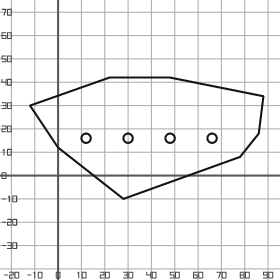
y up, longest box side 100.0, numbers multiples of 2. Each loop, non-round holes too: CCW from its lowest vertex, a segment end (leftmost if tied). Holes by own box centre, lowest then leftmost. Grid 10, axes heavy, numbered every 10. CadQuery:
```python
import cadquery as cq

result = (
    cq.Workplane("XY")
    .moveTo(28.0, -10.0)
    .lineTo(78.0, 8.0)
    .lineTo(86.0, 18.0)
    .lineTo(88.0, 34.0)
    .lineTo(48.0, 42.0)
    .lineTo(22.0, 42.0)
    .lineTo(-12.0, 30.0)
    .lineTo(0.0, 12.0)
    .close()
    .moveTo(12.0, 16.0)
    .circle(2.0)
    .moveTo(30.0, 16.0)
    .circle(2.0)
    .moveTo(48.0, 16.0)
    .circle(2.0)
    .moveTo(66.0, 16.0)
    .circle(2.0)
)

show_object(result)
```